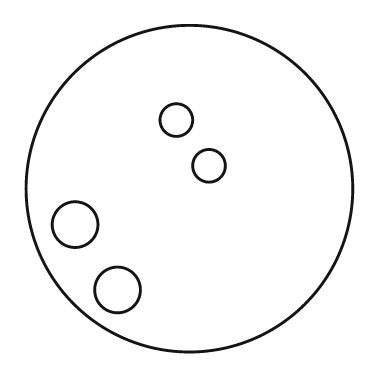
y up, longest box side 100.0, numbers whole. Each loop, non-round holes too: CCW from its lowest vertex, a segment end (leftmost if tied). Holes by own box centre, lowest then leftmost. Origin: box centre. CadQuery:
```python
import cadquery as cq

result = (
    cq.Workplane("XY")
    .moveTo(0.0, 0.0)
    .circle(50.0)
    .moveTo(-22.0, -31.0)
    .circle(7.0)
    .moveTo(-35.0, -11.0)
    .circle(7.0)
    .moveTo(6.0, 7.0)
    .circle(5.0)
    .moveTo(-4.0, 21.0)
    .circle(5.0)
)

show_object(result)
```